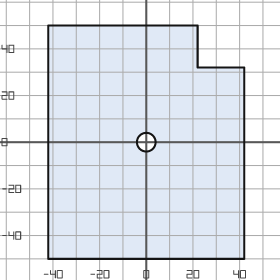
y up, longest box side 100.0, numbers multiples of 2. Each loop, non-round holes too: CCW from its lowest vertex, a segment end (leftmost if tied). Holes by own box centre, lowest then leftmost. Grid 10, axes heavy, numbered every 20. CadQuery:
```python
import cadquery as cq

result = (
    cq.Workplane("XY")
    .moveTo(-42.0, -50.0)
    .lineTo(42.0, -50.0)
    .lineTo(42.0, 32.0)
    .lineTo(22.0, 32.0)
    .lineTo(22.0, 50.0)
    .lineTo(-42.0, 50.0)
    .close()
    .moveTo(0.0, 0.0)
    .circle(4.0)
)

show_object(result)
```